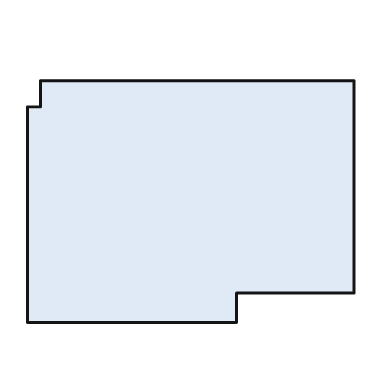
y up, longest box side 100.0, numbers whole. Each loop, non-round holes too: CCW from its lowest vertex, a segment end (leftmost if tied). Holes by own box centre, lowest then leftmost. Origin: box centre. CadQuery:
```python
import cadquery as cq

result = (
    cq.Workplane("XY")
    .moveTo(-50.0, -37.0)
    .lineTo(14.0, -37.0)
    .lineTo(14.0, -28.0)
    .lineTo(50.0, -28.0)
    .lineTo(50.0, 37.0)
    .lineTo(-46.0, 37.0)
    .lineTo(-46.0, 29.0)
    .lineTo(-50.0, 29.0)
    .close()
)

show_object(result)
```